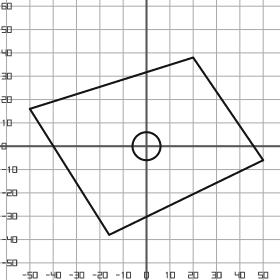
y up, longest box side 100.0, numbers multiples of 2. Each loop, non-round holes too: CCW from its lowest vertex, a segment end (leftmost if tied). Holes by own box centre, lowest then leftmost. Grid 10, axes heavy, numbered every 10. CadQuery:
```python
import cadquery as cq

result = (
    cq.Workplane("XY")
    .moveTo(-16.0, -38.0)
    .lineTo(50.0, -6.0)
    .lineTo(20.0, 38.0)
    .lineTo(-50.0, 16.0)
    .close()
    .moveTo(0.0, 0.0)
    .circle(6.0)
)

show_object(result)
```